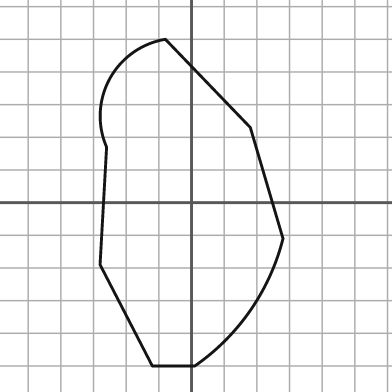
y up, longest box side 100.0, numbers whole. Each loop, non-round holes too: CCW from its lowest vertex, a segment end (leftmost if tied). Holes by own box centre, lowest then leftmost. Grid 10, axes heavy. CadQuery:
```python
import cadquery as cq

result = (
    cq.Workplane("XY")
    .moveTo(-12.0, -50.0)
    .lineTo(1.0, -50.0)
    .threePointArc((18.0, -33.0), (28.0, -11.0))
    .lineTo(18.0, 23.0)
    .lineTo(-8.0, 50.0)
    .threePointArc((-25.0, 38.0), (-26.0, 17.0))
    .lineTo(-28.0, -19.0)
    .close()
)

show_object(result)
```